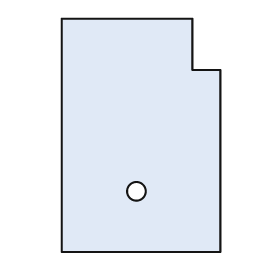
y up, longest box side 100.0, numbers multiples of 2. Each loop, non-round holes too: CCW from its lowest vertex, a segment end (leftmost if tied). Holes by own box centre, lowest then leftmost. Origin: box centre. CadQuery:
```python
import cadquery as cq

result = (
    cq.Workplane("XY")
    .moveTo(-34.0, -50.0)
    .lineTo(34.0, -50.0)
    .lineTo(34.0, 28.0)
    .lineTo(22.0, 28.0)
    .lineTo(22.0, 50.0)
    .lineTo(-34.0, 50.0)
    .close()
    .moveTo(-2.0, -24.0)
    .circle(4.0)
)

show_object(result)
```